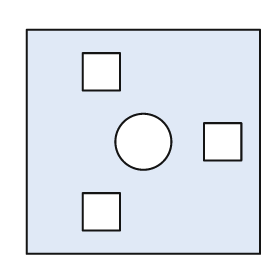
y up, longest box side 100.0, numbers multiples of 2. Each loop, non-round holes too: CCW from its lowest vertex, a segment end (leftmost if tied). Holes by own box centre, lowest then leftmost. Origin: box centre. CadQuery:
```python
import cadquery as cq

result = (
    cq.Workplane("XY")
    .moveTo(-50.0, -48.0)
    .lineTo(50.0, -48.0)
    .lineTo(50.0, 48.0)
    .lineTo(-50.0, 48.0)
    .close()
    .moveTo(-26.0, -38.0)
    .lineTo(-10.0, -38.0)
    .lineTo(-10.0, -22.0)
    .lineTo(-26.0, -22.0)
    .close()
    .moveTo(0.0, 0.0)
    .circle(12.0)
    .moveTo(26.0, -8.0)
    .lineTo(42.0, -8.0)
    .lineTo(42.0, 8.0)
    .lineTo(26.0, 8.0)
    .close()
    .moveTo(-26.0, 22.0)
    .lineTo(-10.0, 22.0)
    .lineTo(-10.0, 38.0)
    .lineTo(-26.0, 38.0)
    .close()
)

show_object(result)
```